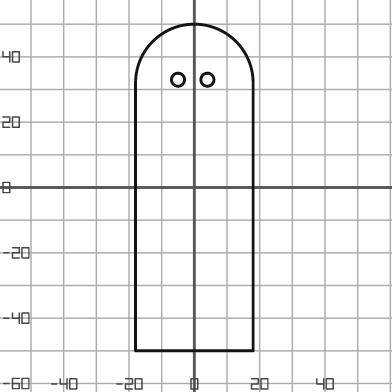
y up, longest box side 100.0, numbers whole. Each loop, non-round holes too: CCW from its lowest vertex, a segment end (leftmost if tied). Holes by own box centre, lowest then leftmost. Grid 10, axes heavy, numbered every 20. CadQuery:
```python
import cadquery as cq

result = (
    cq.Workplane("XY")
    .moveTo(-18.0, -50.0)
    .lineTo(18.0, -50.0)
    .lineTo(18.0, 32.0)
    .threePointArc((0.0, 50.0), (-18.0, 32.0))
    .close()
    .moveTo(-5.0, 33.0)
    .circle(2.0)
    .moveTo(4.0, 33.0)
    .circle(2.0)
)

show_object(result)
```